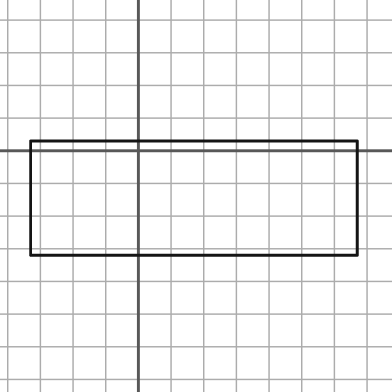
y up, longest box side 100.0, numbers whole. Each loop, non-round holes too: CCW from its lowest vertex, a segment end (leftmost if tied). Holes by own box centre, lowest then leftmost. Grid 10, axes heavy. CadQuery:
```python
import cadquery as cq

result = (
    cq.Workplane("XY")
    .moveTo(-33.0, -32.0)
    .lineTo(67.0, -32.0)
    .lineTo(67.0, 3.0)
    .lineTo(-33.0, 3.0)
    .close()
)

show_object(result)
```